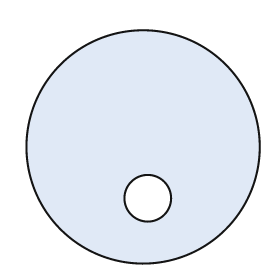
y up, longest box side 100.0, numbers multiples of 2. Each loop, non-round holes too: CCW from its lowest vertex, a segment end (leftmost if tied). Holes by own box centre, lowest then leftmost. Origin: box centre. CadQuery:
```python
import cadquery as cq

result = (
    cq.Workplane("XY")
    .moveTo(0.0, 0.0)
    .circle(50.0)
    .moveTo(2.0, -22.0)
    .circle(10.0)
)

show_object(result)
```